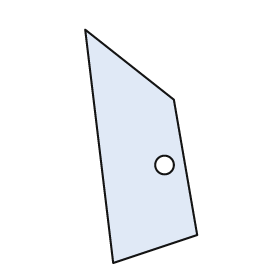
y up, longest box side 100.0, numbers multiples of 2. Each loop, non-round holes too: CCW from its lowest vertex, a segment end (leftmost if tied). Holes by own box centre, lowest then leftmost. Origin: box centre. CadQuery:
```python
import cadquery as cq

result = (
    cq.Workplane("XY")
    .moveTo(-12.0, -50.0)
    .lineTo(24.0, -38.0)
    .lineTo(14.0, 20.0)
    .lineTo(-24.0, 50.0)
    .close()
    .moveTo(10.0, -8.0)
    .circle(4.0)
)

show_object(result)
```